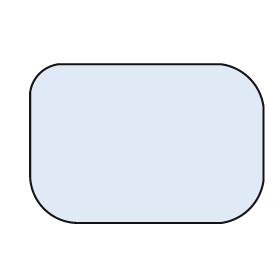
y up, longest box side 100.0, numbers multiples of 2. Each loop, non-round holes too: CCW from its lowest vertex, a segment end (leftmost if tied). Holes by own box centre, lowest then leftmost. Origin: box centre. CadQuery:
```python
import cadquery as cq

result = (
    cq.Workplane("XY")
    .moveTo(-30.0, -34.0)
    .lineTo(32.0, -34.0)
    .threePointArc((44.0, -28.0), (50.0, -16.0))
    .lineTo(50.0, 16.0)
    .threePointArc((44.0, 28.0), (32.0, 34.0))
    .lineTo(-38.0, 34.0)
    .threePointArc((-46.0, 30.0), (-50.0, 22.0))
    .lineTo(-50.0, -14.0)
    .threePointArc((-44.0, -28.0), (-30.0, -34.0))
    .close()
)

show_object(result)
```